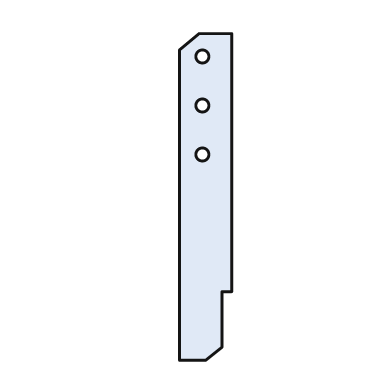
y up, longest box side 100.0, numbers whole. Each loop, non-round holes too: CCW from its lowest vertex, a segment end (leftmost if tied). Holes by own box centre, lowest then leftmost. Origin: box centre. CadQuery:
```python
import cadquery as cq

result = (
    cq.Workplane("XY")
    .moveTo(-8.0, -50.0)
    .lineTo(0.0, -50.0)
    .lineTo(5.0, -46.0)
    .lineTo(5.0, -29.0)
    .lineTo(8.0, -29.0)
    .lineTo(8.0, 50.0)
    .lineTo(-2.0, 50.0)
    .lineTo(-8.0, 45.0)
    .close()
    .moveTo(-1.0, 13.0)
    .circle(2.0)
    .moveTo(-1.0, 28.0)
    .circle(2.0)
    .moveTo(-1.0, 43.0)
    .circle(2.0)
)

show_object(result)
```